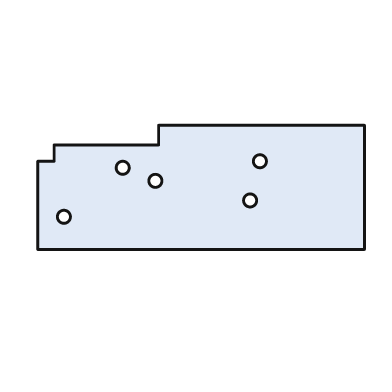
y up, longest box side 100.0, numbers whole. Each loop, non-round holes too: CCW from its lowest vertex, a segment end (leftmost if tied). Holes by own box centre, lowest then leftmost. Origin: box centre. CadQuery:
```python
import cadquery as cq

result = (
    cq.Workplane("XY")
    .moveTo(-50.0, -19.0)
    .lineTo(50.0, -19.0)
    .lineTo(50.0, 19.0)
    .lineTo(-13.0, 19.0)
    .lineTo(-13.0, 13.0)
    .lineTo(-45.0, 13.0)
    .lineTo(-45.0, 8.0)
    .lineTo(-50.0, 8.0)
    .close()
    .moveTo(-42.0, -9.0)
    .circle(2.0)
    .moveTo(15.0, -4.0)
    .circle(2.0)
    .moveTo(-14.0, 2.0)
    .circle(2.0)
    .moveTo(-24.0, 6.0)
    .circle(2.0)
    .moveTo(18.0, 8.0)
    .circle(2.0)
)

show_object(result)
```